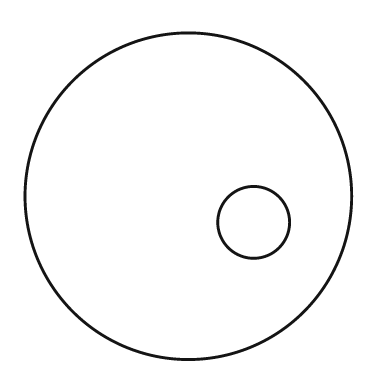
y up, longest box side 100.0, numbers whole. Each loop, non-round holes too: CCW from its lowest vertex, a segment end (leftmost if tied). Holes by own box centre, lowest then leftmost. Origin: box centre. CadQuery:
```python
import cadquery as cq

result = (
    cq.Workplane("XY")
    .moveTo(0.0, 0.0)
    .circle(50.0)
    .moveTo(20.0, -8.0)
    .circle(11.0)
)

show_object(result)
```